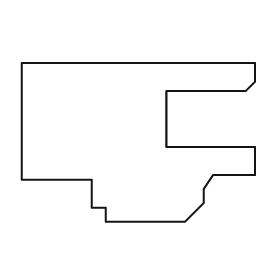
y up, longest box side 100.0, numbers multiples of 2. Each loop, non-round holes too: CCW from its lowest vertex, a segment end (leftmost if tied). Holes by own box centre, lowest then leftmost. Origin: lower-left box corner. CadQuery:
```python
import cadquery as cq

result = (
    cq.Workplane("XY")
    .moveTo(36.0, 0.0)
    .lineTo(70.0, 0.0)
    .lineTo(78.0, 8.0)
    .lineTo(78.0, 14.0)
    .lineTo(82.0, 20.0)
    .lineTo(100.0, 20.0)
    .lineTo(100.0, 32.0)
    .lineTo(62.0, 32.0)
    .lineTo(62.0, 56.0)
    .lineTo(96.0, 56.0)
    .lineTo(100.0, 60.0)
    .lineTo(100.0, 68.0)
    .lineTo(0.0, 68.0)
    .lineTo(0.0, 18.0)
    .lineTo(30.0, 18.0)
    .lineTo(30.0, 6.0)
    .lineTo(36.0, 6.0)
    .close()
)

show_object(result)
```